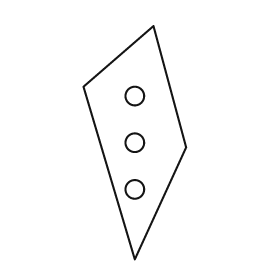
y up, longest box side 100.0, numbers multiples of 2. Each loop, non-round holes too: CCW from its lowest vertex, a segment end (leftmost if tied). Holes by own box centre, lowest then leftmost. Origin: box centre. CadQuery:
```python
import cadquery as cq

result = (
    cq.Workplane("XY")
    .moveTo(0.0, -50.0)
    .lineTo(22.0, -2.0)
    .lineTo(8.0, 50.0)
    .lineTo(-22.0, 24.0)
    .close()
    .moveTo(0.0, -20.0)
    .circle(4.0)
    .moveTo(0.0, 0.0)
    .circle(4.0)
    .moveTo(0.0, 20.0)
    .circle(4.0)
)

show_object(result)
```